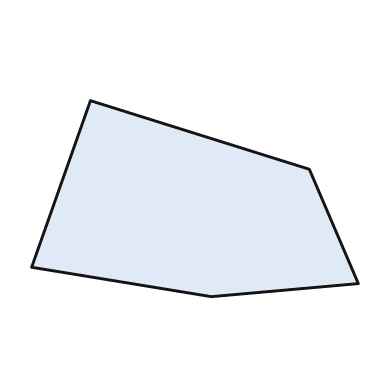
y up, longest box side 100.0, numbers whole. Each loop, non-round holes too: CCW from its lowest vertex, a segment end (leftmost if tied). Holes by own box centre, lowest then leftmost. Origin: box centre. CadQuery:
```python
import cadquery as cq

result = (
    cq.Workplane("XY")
    .moveTo(5.0, -30.0)
    .lineTo(50.0, -26.0)
    .lineTo(35.0, 9.0)
    .lineTo(-32.0, 30.0)
    .lineTo(-50.0, -21.0)
    .close()
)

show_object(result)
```